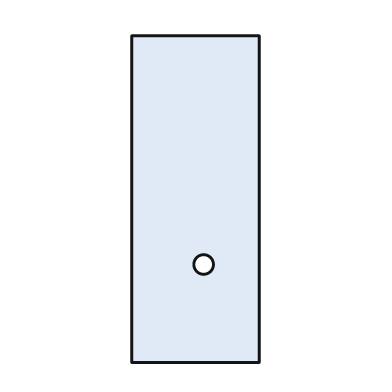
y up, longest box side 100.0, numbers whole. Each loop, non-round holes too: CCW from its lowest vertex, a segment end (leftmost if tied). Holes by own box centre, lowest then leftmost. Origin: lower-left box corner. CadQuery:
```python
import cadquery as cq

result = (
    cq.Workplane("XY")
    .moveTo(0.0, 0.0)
    .lineTo(39.0, 0.0)
    .lineTo(39.0, 100.0)
    .lineTo(0.0, 100.0)
    .close()
    .moveTo(22.0, 30.0)
    .circle(3.0)
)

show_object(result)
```